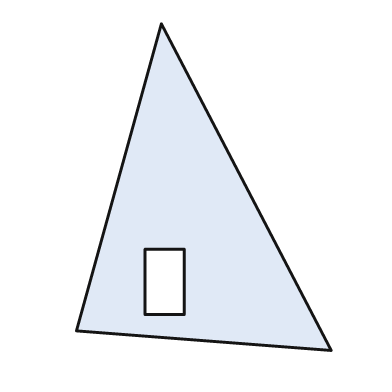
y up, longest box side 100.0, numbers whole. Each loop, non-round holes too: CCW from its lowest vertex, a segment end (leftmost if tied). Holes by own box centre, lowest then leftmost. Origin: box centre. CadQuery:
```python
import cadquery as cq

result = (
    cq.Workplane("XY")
    .moveTo(39.0, -50.0)
    .lineTo(-13.0, 50.0)
    .lineTo(-39.0, -44.0)
    .close()
    .moveTo(-18.0, -39.0)
    .lineTo(-6.0, -39.0)
    .lineTo(-6.0, -19.0)
    .lineTo(-18.0, -19.0)
    .close()
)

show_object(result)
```